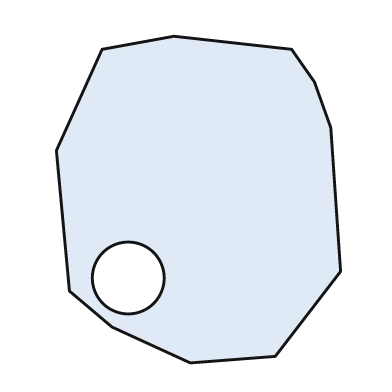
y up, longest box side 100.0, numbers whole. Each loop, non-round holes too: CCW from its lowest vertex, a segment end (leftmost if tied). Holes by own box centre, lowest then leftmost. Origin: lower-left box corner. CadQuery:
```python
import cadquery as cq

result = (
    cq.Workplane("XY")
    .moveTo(41.0, 0.0)
    .lineTo(67.0, 2.0)
    .lineTo(87.0, 28.0)
    .lineTo(84.0, 72.0)
    .lineTo(79.0, 86.0)
    .lineTo(72.0, 96.0)
    .lineTo(36.0, 100.0)
    .lineTo(14.0, 96.0)
    .lineTo(0.0, 65.0)
    .lineTo(4.0, 22.0)
    .lineTo(17.0, 11.0)
    .close()
    .moveTo(22.0, 26.0)
    .circle(11.0)
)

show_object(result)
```